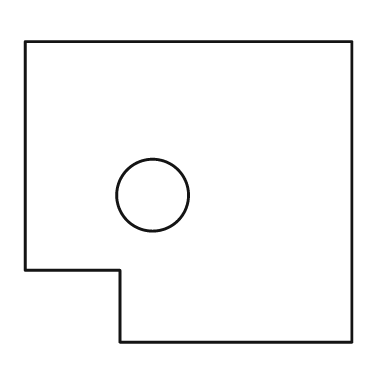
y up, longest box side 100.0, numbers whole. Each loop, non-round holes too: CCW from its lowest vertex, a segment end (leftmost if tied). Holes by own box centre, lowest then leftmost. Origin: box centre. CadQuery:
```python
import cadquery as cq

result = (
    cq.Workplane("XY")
    .moveTo(-21.0, -46.0)
    .lineTo(50.0, -46.0)
    .lineTo(50.0, 46.0)
    .lineTo(-50.0, 46.0)
    .lineTo(-50.0, -24.0)
    .lineTo(-21.0, -24.0)
    .close()
    .moveTo(-11.0, -1.0)
    .circle(11.0)
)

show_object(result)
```